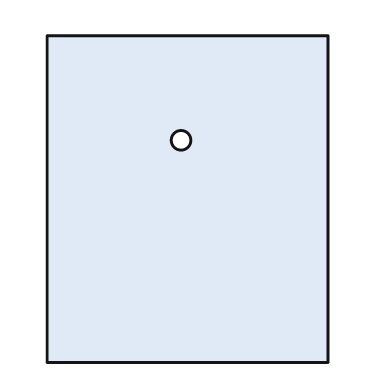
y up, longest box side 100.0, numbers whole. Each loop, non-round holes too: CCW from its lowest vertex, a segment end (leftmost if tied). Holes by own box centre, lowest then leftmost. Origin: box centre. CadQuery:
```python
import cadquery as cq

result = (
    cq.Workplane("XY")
    .moveTo(-43.0, -50.0)
    .lineTo(43.0, -50.0)
    .lineTo(43.0, 50.0)
    .lineTo(-43.0, 50.0)
    .close()
    .moveTo(-2.0, 18.0)
    .circle(3.0)
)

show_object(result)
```